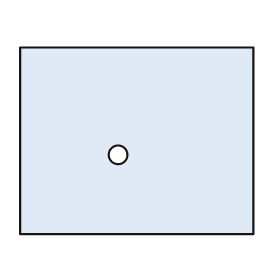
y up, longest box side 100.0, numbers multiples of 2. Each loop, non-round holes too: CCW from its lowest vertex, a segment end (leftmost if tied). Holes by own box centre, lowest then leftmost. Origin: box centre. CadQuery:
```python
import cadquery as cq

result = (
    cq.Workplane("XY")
    .moveTo(-50.0, -40.0)
    .lineTo(50.0, -40.0)
    .lineTo(50.0, 40.0)
    .lineTo(-50.0, 40.0)
    .close()
    .moveTo(-8.0, -6.0)
    .circle(4.0)
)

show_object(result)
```